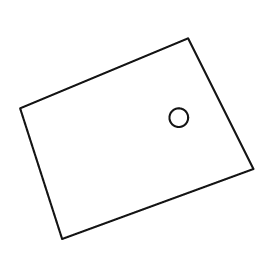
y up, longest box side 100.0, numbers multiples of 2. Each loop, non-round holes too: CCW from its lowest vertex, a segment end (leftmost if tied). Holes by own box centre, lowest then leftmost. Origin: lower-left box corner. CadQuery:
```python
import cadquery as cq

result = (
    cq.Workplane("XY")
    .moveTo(18.0, 0.0)
    .lineTo(100.0, 30.0)
    .lineTo(72.0, 86.0)
    .lineTo(0.0, 56.0)
    .close()
    .moveTo(68.0, 52.0)
    .circle(4.0)
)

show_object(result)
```